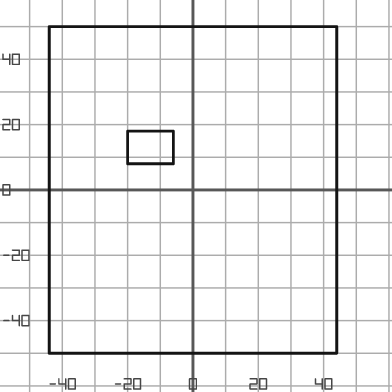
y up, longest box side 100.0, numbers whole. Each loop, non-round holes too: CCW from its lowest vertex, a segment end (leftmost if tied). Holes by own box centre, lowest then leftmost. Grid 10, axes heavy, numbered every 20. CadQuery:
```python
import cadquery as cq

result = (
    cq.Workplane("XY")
    .moveTo(-44.0, -50.0)
    .lineTo(44.0, -50.0)
    .lineTo(44.0, 50.0)
    .lineTo(-44.0, 50.0)
    .close()
    .moveTo(-20.0, 8.0)
    .lineTo(-6.0, 8.0)
    .lineTo(-6.0, 18.0)
    .lineTo(-20.0, 18.0)
    .close()
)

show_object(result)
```